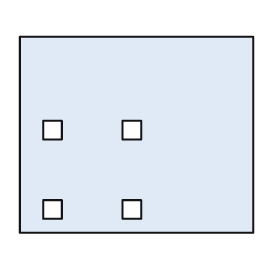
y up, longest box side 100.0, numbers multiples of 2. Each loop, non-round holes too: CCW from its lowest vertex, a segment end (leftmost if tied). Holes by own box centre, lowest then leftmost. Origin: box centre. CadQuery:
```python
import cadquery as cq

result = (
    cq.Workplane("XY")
    .moveTo(-50.0, -42.0)
    .lineTo(50.0, -42.0)
    .lineTo(50.0, 42.0)
    .lineTo(-50.0, 42.0)
    .close()
    .moveTo(-40.0, -36.0)
    .lineTo(-32.0, -36.0)
    .lineTo(-32.0, -28.0)
    .lineTo(-40.0, -28.0)
    .close()
    .moveTo(-6.0, -36.0)
    .lineTo(2.0, -36.0)
    .lineTo(2.0, -28.0)
    .lineTo(-6.0, -28.0)
    .close()
    .moveTo(-40.0, -2.0)
    .lineTo(-32.0, -2.0)
    .lineTo(-32.0, 6.0)
    .lineTo(-40.0, 6.0)
    .close()
    .moveTo(-6.0, -2.0)
    .lineTo(2.0, -2.0)
    .lineTo(2.0, 6.0)
    .lineTo(-6.0, 6.0)
    .close()
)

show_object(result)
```